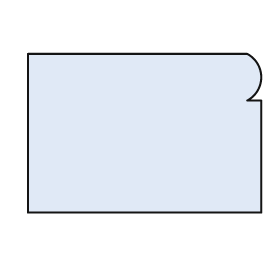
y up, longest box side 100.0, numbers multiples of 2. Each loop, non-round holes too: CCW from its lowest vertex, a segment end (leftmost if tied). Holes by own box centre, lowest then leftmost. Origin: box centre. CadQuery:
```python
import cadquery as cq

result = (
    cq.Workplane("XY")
    .moveTo(-50.0, -34.0)
    .lineTo(50.0, -34.0)
    .lineTo(50.0, 14.0)
    .lineTo(44.0, 14.0)
    .threePointArc((50.0, 24.0), (44.0, 34.0))
    .lineTo(-50.0, 34.0)
    .close()
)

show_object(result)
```